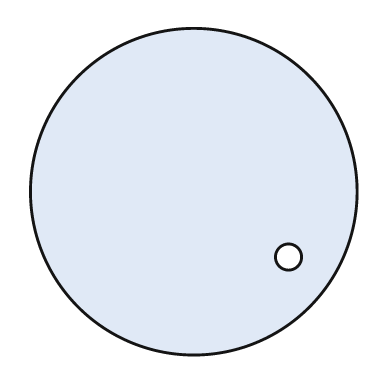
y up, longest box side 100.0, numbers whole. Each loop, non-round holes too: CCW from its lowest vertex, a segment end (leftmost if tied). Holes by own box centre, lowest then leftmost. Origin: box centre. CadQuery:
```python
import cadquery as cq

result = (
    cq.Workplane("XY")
    .moveTo(0.0, 0.0)
    .circle(50.0)
    .moveTo(29.0, -20.0)
    .circle(4.0)
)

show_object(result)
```